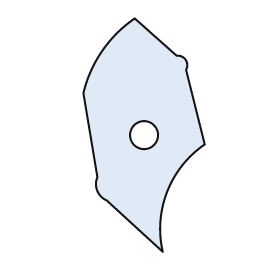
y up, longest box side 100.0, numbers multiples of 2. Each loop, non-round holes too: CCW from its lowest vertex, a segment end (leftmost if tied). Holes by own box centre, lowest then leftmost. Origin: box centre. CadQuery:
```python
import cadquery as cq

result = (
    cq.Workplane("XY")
    .moveTo(8.0, -50.0)
    .threePointArc((10.0, -24.0), (26.0, -4.0))
    .lineTo(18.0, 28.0)
    .threePointArc((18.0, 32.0), (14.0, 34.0))
    .lineTo(-4.0, 50.0)
    .threePointArc((-18.0, 36.0), (-26.0, 18.0))
    .lineTo(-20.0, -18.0)
    .threePointArc((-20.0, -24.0), (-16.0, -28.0))
    .close()
    .moveTo(0.0, 0.0)
    .circle(6.0)
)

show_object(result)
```